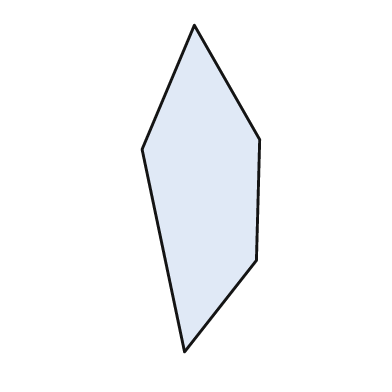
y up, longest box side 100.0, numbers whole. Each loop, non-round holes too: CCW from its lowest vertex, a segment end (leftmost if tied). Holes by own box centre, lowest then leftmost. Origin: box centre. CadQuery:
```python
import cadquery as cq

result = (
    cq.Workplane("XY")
    .moveTo(-5.0, -50.0)
    .lineTo(17.0, -22.0)
    .lineTo(18.0, 15.0)
    .lineTo(-2.0, 50.0)
    .lineTo(-18.0, 12.0)
    .close()
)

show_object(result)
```